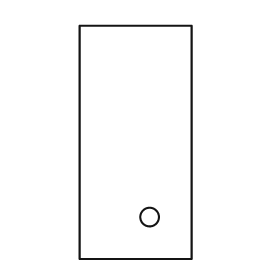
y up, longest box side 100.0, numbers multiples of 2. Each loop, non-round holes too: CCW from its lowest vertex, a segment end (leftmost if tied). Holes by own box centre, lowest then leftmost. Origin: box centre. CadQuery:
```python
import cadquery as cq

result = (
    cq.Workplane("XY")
    .moveTo(-24.0, -50.0)
    .lineTo(24.0, -50.0)
    .lineTo(24.0, 50.0)
    .lineTo(-24.0, 50.0)
    .close()
    .moveTo(6.0, -32.0)
    .circle(4.0)
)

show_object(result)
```